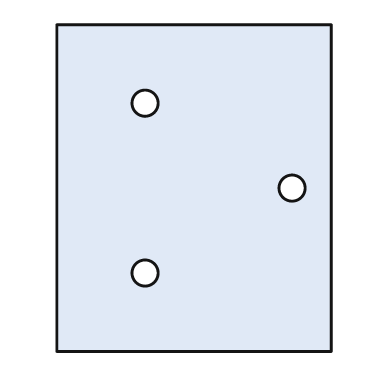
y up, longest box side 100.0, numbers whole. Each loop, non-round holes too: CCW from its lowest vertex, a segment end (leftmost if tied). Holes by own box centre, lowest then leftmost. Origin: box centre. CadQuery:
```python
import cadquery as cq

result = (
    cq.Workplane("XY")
    .moveTo(-42.0, -50.0)
    .lineTo(42.0, -50.0)
    .lineTo(42.0, 50.0)
    .lineTo(-42.0, 50.0)
    .close()
    .moveTo(-15.0, -26.0)
    .circle(4.0)
    .moveTo(30.0, 0.0)
    .circle(4.0)
    .moveTo(-15.0, 26.0)
    .circle(4.0)
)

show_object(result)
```